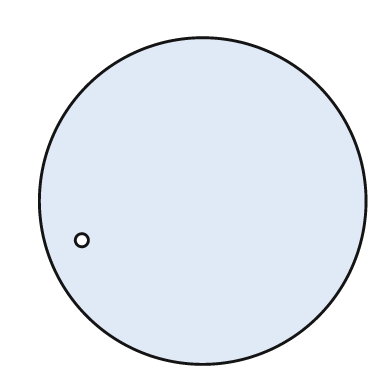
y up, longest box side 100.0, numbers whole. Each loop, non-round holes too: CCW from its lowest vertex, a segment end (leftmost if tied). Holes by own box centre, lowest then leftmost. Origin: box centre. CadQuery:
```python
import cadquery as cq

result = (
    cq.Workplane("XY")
    .moveTo(0.0, 0.0)
    .circle(50.0)
    .moveTo(-37.0, -12.0)
    .circle(2.0)
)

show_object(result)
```